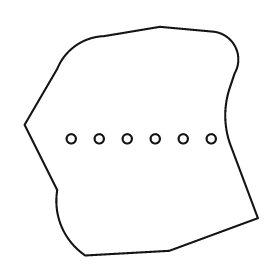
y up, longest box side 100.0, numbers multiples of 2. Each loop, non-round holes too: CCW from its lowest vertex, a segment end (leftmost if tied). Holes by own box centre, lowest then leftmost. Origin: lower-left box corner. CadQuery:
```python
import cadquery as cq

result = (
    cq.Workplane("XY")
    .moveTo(26.0, 0.0)
    .lineTo(62.0, 2.0)
    .lineTo(100.0, 16.0)
    .lineTo(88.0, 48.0)
    .threePointArc((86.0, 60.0), (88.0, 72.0))
    .lineTo(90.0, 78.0)
    .threePointArc((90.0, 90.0), (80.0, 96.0))
    .lineTo(58.0, 98.0)
    .lineTo(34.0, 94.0)
    .threePointArc((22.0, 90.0), (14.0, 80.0))
    .lineTo(0.0, 56.0)
    .lineTo(14.0, 28.0)
    .threePointArc((16.0, 12.0), (26.0, 0.0))
    .close()
    .moveTo(20.0, 50.0)
    .circle(2.0)
    .moveTo(32.0, 50.0)
    .circle(2.0)
    .moveTo(44.0, 50.0)
    .circle(2.0)
    .moveTo(56.0, 50.0)
    .circle(2.0)
    .moveTo(68.0, 50.0)
    .circle(2.0)
    .moveTo(80.0, 50.0)
    .circle(2.0)
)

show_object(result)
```